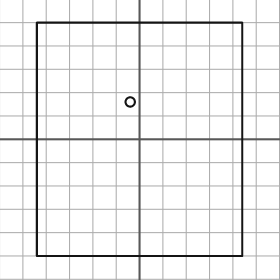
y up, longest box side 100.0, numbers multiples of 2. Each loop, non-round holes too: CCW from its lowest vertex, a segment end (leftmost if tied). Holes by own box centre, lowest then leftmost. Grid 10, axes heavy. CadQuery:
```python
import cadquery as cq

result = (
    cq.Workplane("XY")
    .moveTo(-44.0, -50.0)
    .lineTo(44.0, -50.0)
    .lineTo(44.0, 50.0)
    .lineTo(-44.0, 50.0)
    .close()
    .moveTo(-4.0, 16.0)
    .circle(2.0)
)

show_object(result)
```